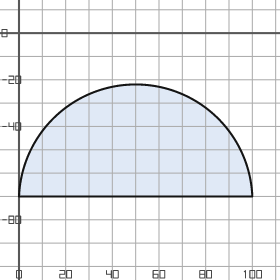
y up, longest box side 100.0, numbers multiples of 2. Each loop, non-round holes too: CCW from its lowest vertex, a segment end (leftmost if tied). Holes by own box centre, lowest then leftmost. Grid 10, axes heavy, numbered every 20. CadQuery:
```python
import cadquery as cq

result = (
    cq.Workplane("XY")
    .moveTo(0.0, -70.0)
    .lineTo(100.0, -70.0)
    .threePointArc((50.0, -22.0), (0.0, -70.0))
    .close()
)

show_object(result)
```